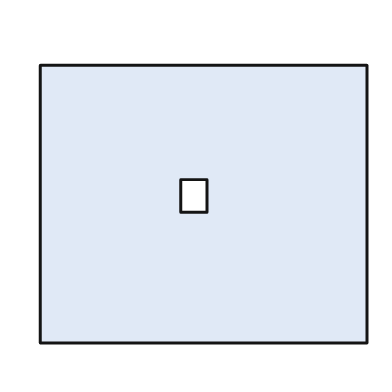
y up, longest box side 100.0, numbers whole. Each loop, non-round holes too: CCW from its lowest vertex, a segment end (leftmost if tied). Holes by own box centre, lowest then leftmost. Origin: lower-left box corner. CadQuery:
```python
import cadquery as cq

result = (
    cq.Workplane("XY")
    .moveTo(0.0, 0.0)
    .lineTo(100.0, 0.0)
    .lineTo(100.0, 85.0)
    .lineTo(0.0, 85.0)
    .close()
    .moveTo(43.0, 40.0)
    .lineTo(51.0, 40.0)
    .lineTo(51.0, 50.0)
    .lineTo(43.0, 50.0)
    .close()
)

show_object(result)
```